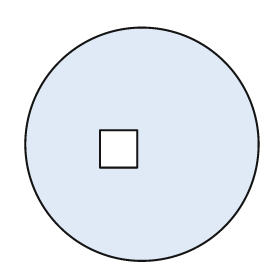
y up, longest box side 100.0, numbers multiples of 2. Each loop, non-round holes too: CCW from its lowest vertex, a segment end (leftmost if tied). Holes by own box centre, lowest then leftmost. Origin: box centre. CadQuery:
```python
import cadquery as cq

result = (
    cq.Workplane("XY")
    .moveTo(0.0, 0.0)
    .circle(50.0)
    .moveTo(-18.0, -10.0)
    .lineTo(-2.0, -10.0)
    .lineTo(-2.0, 6.0)
    .lineTo(-18.0, 6.0)
    .close()
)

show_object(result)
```